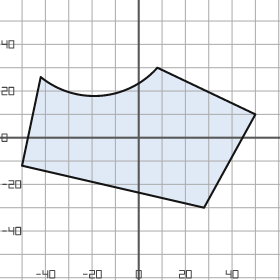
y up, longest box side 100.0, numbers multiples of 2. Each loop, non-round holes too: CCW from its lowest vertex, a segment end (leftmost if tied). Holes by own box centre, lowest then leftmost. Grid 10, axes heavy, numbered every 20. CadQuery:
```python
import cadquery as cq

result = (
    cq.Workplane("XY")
    .moveTo(28.0, -30.0)
    .lineTo(50.0, 10.0)
    .lineTo(8.0, 30.0)
    .threePointArc((-16.0, 18.0), (-42.0, 26.0))
    .lineTo(-50.0, -12.0)
    .close()
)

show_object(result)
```